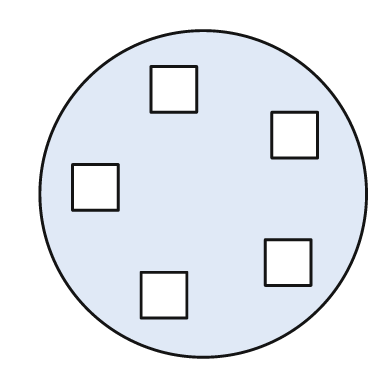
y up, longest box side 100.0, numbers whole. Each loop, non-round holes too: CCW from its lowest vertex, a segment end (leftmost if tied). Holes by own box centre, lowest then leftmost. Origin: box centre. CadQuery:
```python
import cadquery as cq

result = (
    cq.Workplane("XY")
    .moveTo(0.0, 0.0)
    .circle(50.0)
    .moveTo(-19.0, -38.0)
    .lineTo(-5.0, -38.0)
    .lineTo(-5.0, -24.0)
    .lineTo(-19.0, -24.0)
    .close()
    .moveTo(19.0, -28.0)
    .lineTo(33.0, -28.0)
    .lineTo(33.0, -14.0)
    .lineTo(19.0, -14.0)
    .close()
    .moveTo(-40.0, -5.0)
    .lineTo(-26.0, -5.0)
    .lineTo(-26.0, 9.0)
    .lineTo(-40.0, 9.0)
    .close()
    .moveTo(21.0, 11.0)
    .lineTo(35.0, 11.0)
    .lineTo(35.0, 25.0)
    .lineTo(21.0, 25.0)
    .close()
    .moveTo(-16.0, 25.0)
    .lineTo(-2.0, 25.0)
    .lineTo(-2.0, 39.0)
    .lineTo(-16.0, 39.0)
    .close()
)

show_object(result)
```